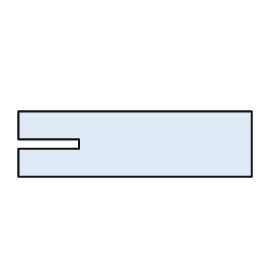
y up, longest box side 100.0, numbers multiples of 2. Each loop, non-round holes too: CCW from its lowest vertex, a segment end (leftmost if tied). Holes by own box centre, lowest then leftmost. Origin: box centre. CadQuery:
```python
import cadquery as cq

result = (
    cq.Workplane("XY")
    .moveTo(-50.0, -14.0)
    .lineTo(50.0, -14.0)
    .lineTo(50.0, 14.0)
    .lineTo(-50.0, 14.0)
    .lineTo(-50.0, 2.0)
    .lineTo(-24.0, 2.0)
    .lineTo(-24.0, -2.0)
    .lineTo(-50.0, -2.0)
    .close()
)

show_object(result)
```